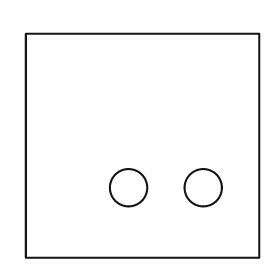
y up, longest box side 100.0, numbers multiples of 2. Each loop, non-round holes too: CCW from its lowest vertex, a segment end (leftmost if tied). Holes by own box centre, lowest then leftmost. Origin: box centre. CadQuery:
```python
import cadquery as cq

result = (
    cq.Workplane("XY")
    .moveTo(-50.0, -48.0)
    .lineTo(50.0, -48.0)
    .lineTo(50.0, 48.0)
    .lineTo(-50.0, 48.0)
    .close()
    .moveTo(-6.0, -18.0)
    .circle(8.0)
    .moveTo(26.0, -18.0)
    .circle(8.0)
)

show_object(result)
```